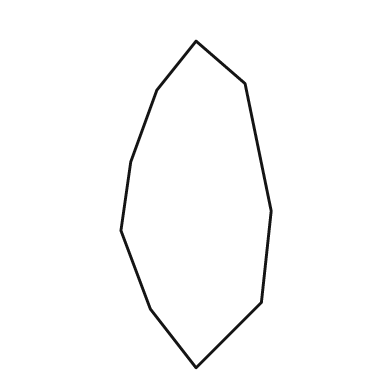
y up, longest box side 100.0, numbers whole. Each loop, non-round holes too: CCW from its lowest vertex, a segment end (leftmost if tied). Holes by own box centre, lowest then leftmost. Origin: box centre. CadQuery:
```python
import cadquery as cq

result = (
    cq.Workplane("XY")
    .moveTo(0.0, -50.0)
    .lineTo(20.0, -30.0)
    .lineTo(23.0, -2.0)
    .lineTo(15.0, 37.0)
    .lineTo(0.0, 50.0)
    .lineTo(-12.0, 35.0)
    .lineTo(-20.0, 13.0)
    .lineTo(-23.0, -8.0)
    .lineTo(-14.0, -32.0)
    .close()
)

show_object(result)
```